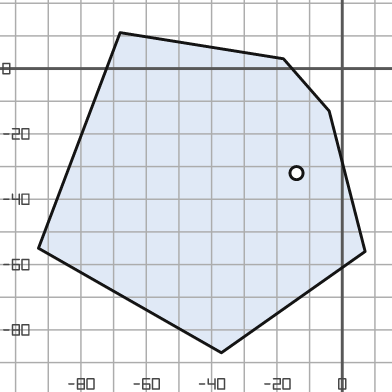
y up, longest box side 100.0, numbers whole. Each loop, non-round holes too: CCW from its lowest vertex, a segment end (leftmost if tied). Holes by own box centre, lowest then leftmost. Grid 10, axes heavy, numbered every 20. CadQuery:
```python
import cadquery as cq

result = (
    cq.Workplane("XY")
    .moveTo(-37.0, -87.0)
    .lineTo(7.0, -56.0)
    .lineTo(-4.0, -13.0)
    .lineTo(-18.0, 3.0)
    .lineTo(-68.0, 11.0)
    .lineTo(-93.0, -55.0)
    .close()
    .moveTo(-14.0, -32.0)
    .circle(2.0)
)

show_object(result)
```